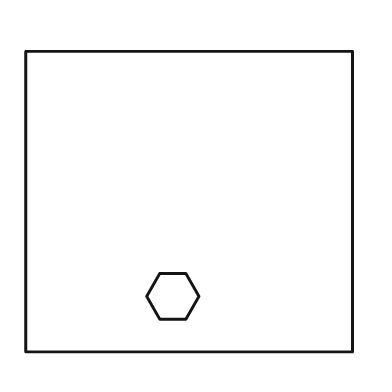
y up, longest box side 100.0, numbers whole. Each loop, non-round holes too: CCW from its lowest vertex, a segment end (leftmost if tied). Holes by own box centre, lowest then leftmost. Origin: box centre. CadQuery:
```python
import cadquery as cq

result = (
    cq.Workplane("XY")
    .moveTo(-50.0, -46.0)
    .lineTo(50.0, -46.0)
    .lineTo(50.0, 46.0)
    .lineTo(-50.0, 46.0)
    .close()
    .moveTo(-9.0, -36.0)
    .lineTo(-1.0, -36.0)
    .lineTo(3.0, -29.0)
    .lineTo(-1.0, -22.0)
    .lineTo(-9.0, -22.0)
    .lineTo(-13.0, -29.0)
    .close()
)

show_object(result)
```